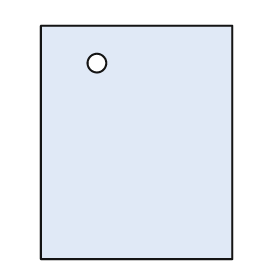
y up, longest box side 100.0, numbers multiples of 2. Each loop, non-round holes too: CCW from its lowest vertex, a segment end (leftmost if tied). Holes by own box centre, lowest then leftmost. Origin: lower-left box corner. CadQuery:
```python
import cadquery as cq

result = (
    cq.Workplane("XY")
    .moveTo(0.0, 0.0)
    .lineTo(82.0, 0.0)
    .lineTo(82.0, 100.0)
    .lineTo(0.0, 100.0)
    .close()
    .moveTo(24.0, 84.0)
    .circle(4.0)
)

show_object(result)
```